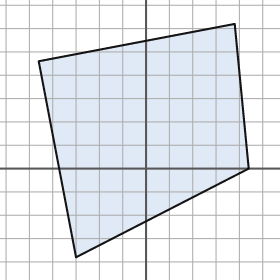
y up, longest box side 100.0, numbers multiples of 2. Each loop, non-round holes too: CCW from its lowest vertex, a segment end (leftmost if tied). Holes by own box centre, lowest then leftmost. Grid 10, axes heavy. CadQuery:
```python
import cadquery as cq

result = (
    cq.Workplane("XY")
    .moveTo(-30.0, -38.0)
    .lineTo(44.0, 0.0)
    .lineTo(38.0, 62.0)
    .lineTo(-46.0, 46.0)
    .close()
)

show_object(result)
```